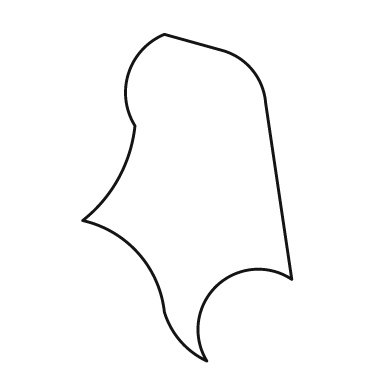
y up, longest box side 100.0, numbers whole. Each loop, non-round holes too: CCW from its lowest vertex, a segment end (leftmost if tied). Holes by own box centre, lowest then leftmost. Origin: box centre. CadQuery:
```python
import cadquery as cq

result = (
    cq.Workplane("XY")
    .moveTo(6.0, -50.0)
    .threePointArc((9.0, -27.0), (32.0, -25.0))
    .lineTo(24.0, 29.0)
    .threePointArc((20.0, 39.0), (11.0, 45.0))
    .lineTo(-7.0, 50.0)
    .threePointArc((-18.0, 38.0), (-16.0, 22.0))
    .threePointArc((-21.0, 6.0), (-32.0, -7.0))
    .threePointArc((-15.0, -17.0), (-7.0, -35.0))
    .threePointArc((-2.0, -44.0), (6.0, -50.0))
    .close()
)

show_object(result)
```